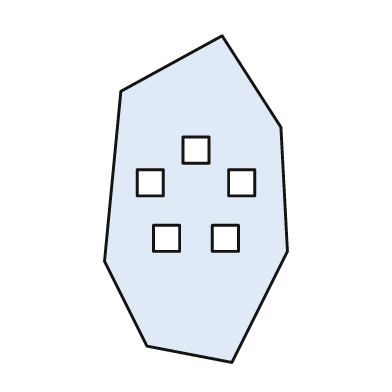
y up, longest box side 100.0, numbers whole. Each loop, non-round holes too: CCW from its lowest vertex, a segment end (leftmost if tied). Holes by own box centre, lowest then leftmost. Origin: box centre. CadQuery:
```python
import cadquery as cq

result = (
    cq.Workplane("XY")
    .moveTo(11.0, -50.0)
    .lineTo(28.0, -16.0)
    .lineTo(26.0, 22.0)
    .lineTo(8.0, 50.0)
    .lineTo(-23.0, 33.0)
    .lineTo(-28.0, -19.0)
    .lineTo(-15.0, -45.0)
    .close()
    .moveTo(-13.0, -16.0)
    .lineTo(-5.0, -16.0)
    .lineTo(-5.0, -8.0)
    .lineTo(-13.0, -8.0)
    .close()
    .moveTo(5.0, -16.0)
    .lineTo(13.0, -16.0)
    .lineTo(13.0, -8.0)
    .lineTo(5.0, -8.0)
    .close()
    .moveTo(-18.0, 1.0)
    .lineTo(-10.0, 1.0)
    .lineTo(-10.0, 9.0)
    .lineTo(-18.0, 9.0)
    .close()
    .moveTo(10.0, 1.0)
    .lineTo(18.0, 1.0)
    .lineTo(18.0, 9.0)
    .lineTo(10.0, 9.0)
    .close()
    .moveTo(-4.0, 11.0)
    .lineTo(4.0, 11.0)
    .lineTo(4.0, 19.0)
    .lineTo(-4.0, 19.0)
    .close()
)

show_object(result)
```